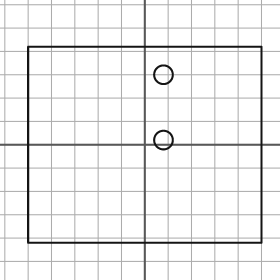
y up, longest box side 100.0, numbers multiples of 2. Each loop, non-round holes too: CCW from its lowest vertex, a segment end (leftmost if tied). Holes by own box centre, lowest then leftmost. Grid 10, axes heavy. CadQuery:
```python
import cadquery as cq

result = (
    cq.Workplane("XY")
    .moveTo(-50.0, -42.0)
    .lineTo(50.0, -42.0)
    .lineTo(50.0, 42.0)
    .lineTo(-50.0, 42.0)
    .close()
    .moveTo(8.0, 2.0)
    .circle(4.0)
    .moveTo(8.0, 30.0)
    .circle(4.0)
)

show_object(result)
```